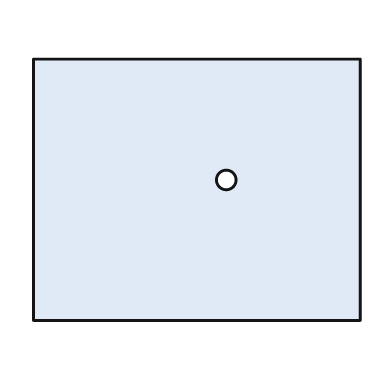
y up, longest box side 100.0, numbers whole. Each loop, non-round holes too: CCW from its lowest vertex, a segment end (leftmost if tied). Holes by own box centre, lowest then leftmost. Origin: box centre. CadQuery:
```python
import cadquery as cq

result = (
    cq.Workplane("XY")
    .moveTo(-50.0, -40.0)
    .lineTo(50.0, -40.0)
    .lineTo(50.0, 40.0)
    .lineTo(-50.0, 40.0)
    .close()
    .moveTo(9.0, 3.0)
    .circle(3.0)
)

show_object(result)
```